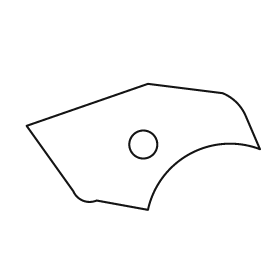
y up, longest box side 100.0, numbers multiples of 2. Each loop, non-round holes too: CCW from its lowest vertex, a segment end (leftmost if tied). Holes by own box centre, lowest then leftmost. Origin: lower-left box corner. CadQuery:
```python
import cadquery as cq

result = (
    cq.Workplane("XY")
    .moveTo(52.0, 0.0)
    .threePointArc((70.0, 24.0), (100.0, 26.0))
    .lineTo(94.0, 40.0)
    .threePointArc((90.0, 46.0), (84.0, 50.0))
    .lineTo(52.0, 54.0)
    .lineTo(0.0, 36.0)
    .lineTo(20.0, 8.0)
    .threePointArc((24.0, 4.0), (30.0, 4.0))
    .close()
    .moveTo(50.0, 28.0)
    .circle(6.0)
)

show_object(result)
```